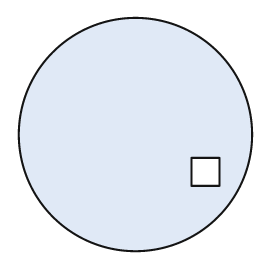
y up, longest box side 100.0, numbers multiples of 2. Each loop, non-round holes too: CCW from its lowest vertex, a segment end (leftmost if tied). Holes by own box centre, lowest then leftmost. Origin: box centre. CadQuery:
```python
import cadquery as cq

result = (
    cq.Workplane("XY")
    .moveTo(0.0, 0.0)
    .circle(50.0)
    .moveTo(24.0, -22.0)
    .lineTo(36.0, -22.0)
    .lineTo(36.0, -10.0)
    .lineTo(24.0, -10.0)
    .close()
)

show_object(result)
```